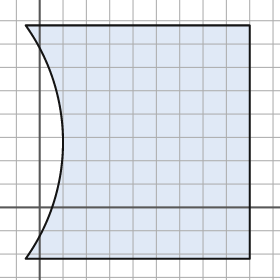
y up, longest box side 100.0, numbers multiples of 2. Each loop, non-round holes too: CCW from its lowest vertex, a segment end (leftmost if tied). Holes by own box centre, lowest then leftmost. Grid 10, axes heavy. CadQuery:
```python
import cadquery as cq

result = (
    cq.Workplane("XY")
    .moveTo(-6.0, -22.0)
    .lineTo(90.0, -22.0)
    .lineTo(90.0, 78.0)
    .lineTo(-6.0, 78.0)
    .threePointArc((10.0, 28.0), (-6.0, -22.0))
    .close()
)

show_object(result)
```